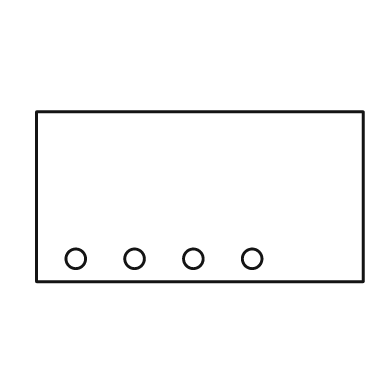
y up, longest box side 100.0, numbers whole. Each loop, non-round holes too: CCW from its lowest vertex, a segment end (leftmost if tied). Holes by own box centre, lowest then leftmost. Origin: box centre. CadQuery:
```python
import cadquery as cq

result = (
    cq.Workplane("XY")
    .moveTo(-50.0, -26.0)
    .lineTo(50.0, -26.0)
    .lineTo(50.0, 26.0)
    .lineTo(-50.0, 26.0)
    .close()
    .moveTo(-38.0, -19.0)
    .circle(3.0)
    .moveTo(-20.0, -19.0)
    .circle(3.0)
    .moveTo(-2.0, -19.0)
    .circle(3.0)
    .moveTo(16.0, -19.0)
    .circle(3.0)
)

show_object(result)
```